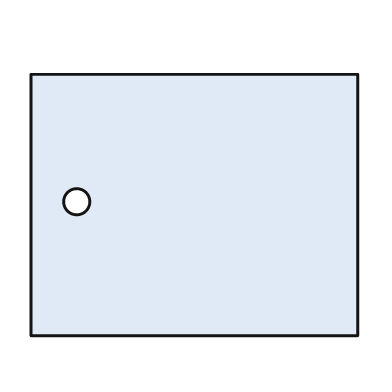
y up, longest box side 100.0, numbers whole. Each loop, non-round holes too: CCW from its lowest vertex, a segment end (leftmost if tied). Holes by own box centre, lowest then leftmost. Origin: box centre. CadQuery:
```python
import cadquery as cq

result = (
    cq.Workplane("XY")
    .moveTo(-50.0, -40.0)
    .lineTo(50.0, -40.0)
    .lineTo(50.0, 40.0)
    .lineTo(-50.0, 40.0)
    .close()
    .moveTo(-36.0, 1.0)
    .circle(4.0)
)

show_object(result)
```